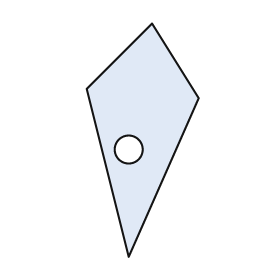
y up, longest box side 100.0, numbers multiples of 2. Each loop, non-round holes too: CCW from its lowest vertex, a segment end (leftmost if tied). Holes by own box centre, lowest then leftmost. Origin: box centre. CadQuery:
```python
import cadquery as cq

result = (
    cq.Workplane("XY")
    .moveTo(-6.0, -50.0)
    .lineTo(24.0, 18.0)
    .lineTo(4.0, 50.0)
    .lineTo(-24.0, 22.0)
    .close()
    .moveTo(-6.0, -4.0)
    .circle(6.0)
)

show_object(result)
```